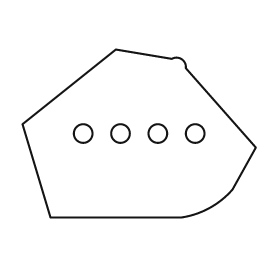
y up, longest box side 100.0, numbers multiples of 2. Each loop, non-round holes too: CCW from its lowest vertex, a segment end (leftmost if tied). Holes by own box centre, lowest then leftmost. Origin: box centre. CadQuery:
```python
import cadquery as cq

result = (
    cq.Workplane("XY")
    .moveTo(-38.0, -36.0)
    .lineTo(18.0, -36.0)
    .threePointArc((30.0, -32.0), (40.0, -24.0))
    .lineTo(50.0, -6.0)
    .lineTo(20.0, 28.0)
    .threePointArc((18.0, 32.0), (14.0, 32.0))
    .lineTo(-10.0, 36.0)
    .lineTo(-50.0, 4.0)
    .close()
    .moveTo(-24.0, 0.0)
    .circle(4.0)
    .moveTo(-8.0, 0.0)
    .circle(4.0)
    .moveTo(8.0, 0.0)
    .circle(4.0)
    .moveTo(24.0, 0.0)
    .circle(4.0)
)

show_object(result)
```